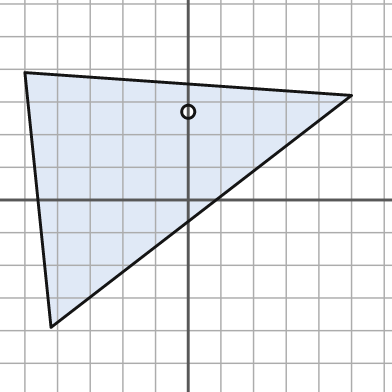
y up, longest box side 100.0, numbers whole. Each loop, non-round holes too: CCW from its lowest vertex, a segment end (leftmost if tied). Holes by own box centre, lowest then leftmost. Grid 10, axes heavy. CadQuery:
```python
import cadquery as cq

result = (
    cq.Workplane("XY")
    .moveTo(-42.0, -39.0)
    .lineTo(50.0, 32.0)
    .lineTo(-50.0, 39.0)
    .close()
    .moveTo(0.0, 27.0)
    .circle(2.0)
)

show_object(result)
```